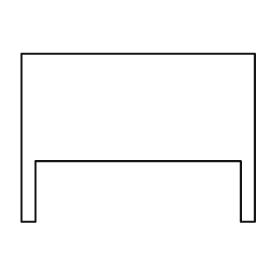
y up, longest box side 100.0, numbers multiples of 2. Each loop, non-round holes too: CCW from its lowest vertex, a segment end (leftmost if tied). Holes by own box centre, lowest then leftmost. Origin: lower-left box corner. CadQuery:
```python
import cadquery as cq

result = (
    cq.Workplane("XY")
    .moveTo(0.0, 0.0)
    .lineTo(6.0, 0.0)
    .lineTo(6.0, 26.0)
    .lineTo(94.0, 26.0)
    .lineTo(94.0, 0.0)
    .lineTo(100.0, 0.0)
    .lineTo(100.0, 72.0)
    .lineTo(0.0, 72.0)
    .close()
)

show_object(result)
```